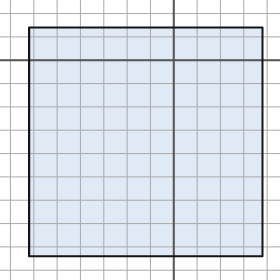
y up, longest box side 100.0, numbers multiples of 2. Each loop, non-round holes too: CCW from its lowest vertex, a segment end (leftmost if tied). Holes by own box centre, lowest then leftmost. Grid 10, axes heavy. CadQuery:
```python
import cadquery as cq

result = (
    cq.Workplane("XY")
    .moveTo(-62.0, -84.0)
    .lineTo(38.0, -84.0)
    .lineTo(38.0, 14.0)
    .lineTo(-62.0, 14.0)
    .close()
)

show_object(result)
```